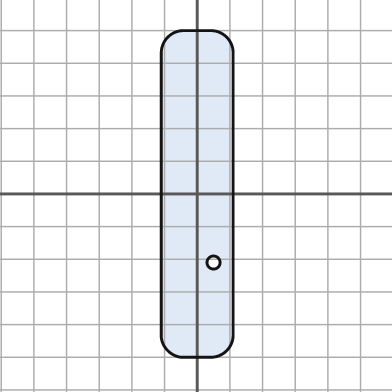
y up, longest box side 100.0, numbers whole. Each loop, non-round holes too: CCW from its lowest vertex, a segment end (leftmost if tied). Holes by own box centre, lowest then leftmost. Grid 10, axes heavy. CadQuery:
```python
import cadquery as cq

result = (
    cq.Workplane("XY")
    .moveTo(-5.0, -50.0)
    .lineTo(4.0, -50.0)
    .threePointArc((9.0, -48.0), (11.0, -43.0))
    .lineTo(11.0, 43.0)
    .threePointArc((9.0, 48.0), (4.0, 50.0))
    .lineTo(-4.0, 50.0)
    .threePointArc((-9.0, 48.0), (-11.0, 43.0))
    .lineTo(-11.0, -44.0)
    .threePointArc((-9.0, -48.0), (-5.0, -50.0))
    .close()
    .moveTo(5.0, -21.0)
    .circle(2.0)
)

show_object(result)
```